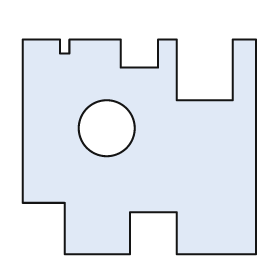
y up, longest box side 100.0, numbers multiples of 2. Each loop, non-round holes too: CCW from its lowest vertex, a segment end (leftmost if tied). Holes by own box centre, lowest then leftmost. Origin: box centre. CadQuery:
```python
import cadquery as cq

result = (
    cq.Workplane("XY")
    .moveTo(-32.0, -46.0)
    .lineTo(-4.0, -46.0)
    .lineTo(-4.0, -28.0)
    .lineTo(16.0, -28.0)
    .lineTo(16.0, -46.0)
    .lineTo(50.0, -46.0)
    .lineTo(50.0, 46.0)
    .lineTo(40.0, 46.0)
    .lineTo(40.0, 20.0)
    .lineTo(16.0, 20.0)
    .lineTo(16.0, 46.0)
    .lineTo(8.0, 46.0)
    .lineTo(8.0, 34.0)
    .lineTo(-8.0, 34.0)
    .lineTo(-8.0, 46.0)
    .lineTo(-30.0, 46.0)
    .lineTo(-30.0, 40.0)
    .lineTo(-34.0, 40.0)
    .lineTo(-34.0, 46.0)
    .lineTo(-50.0, 46.0)
    .lineTo(-50.0, -24.0)
    .lineTo(-32.0, -24.0)
    .close()
    .moveTo(-14.0, 8.0)
    .circle(12.0)
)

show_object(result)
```